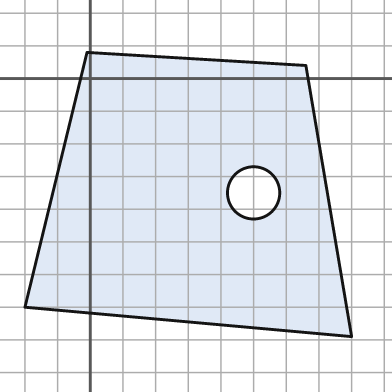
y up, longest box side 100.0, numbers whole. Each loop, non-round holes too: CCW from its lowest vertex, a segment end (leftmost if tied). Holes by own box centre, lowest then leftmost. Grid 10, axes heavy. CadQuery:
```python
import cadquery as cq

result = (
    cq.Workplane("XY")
    .moveTo(80.0, -79.0)
    .lineTo(66.0, 4.0)
    .lineTo(-1.0, 8.0)
    .lineTo(-20.0, -70.0)
    .close()
    .moveTo(50.0, -35.0)
    .circle(8.0)
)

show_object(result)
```